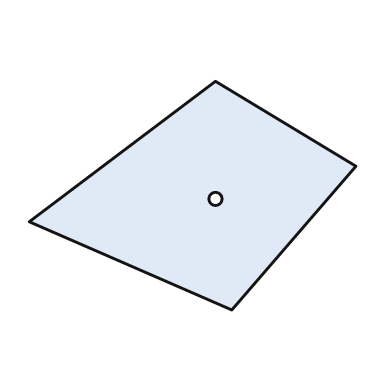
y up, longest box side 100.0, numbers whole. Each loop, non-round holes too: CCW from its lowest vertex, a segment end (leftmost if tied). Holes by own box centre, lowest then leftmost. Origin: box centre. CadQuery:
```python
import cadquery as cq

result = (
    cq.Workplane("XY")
    .moveTo(12.0, -35.0)
    .lineTo(50.0, 9.0)
    .lineTo(7.0, 35.0)
    .lineTo(-50.0, -8.0)
    .close()
    .moveTo(7.0, -1.0)
    .circle(2.0)
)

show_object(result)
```